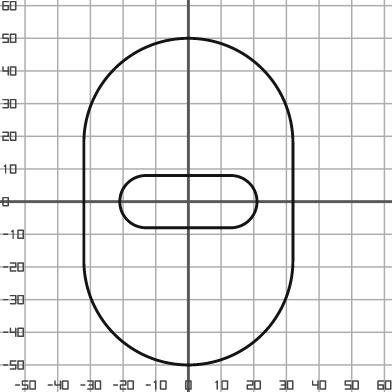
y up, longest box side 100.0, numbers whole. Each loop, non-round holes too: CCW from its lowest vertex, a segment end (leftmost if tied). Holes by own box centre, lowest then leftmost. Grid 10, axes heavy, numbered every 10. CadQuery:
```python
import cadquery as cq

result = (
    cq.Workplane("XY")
    .moveTo(-32.0, -18.0)
    .threePointArc((0.0, -50.0), (32.0, -18.0))
    .lineTo(32.0, 18.0)
    .threePointArc((0.0, 50.0), (-32.0, 18.0))
    .close()
    .moveTo(-13.0, -8.0)
    .lineTo(13.0, -8.0)
    .threePointArc((21.0, 0.0), (13.0, 8.0))
    .lineTo(-13.0, 8.0)
    .threePointArc((-21.0, 0.0), (-13.0, -8.0))
    .close()
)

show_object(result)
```